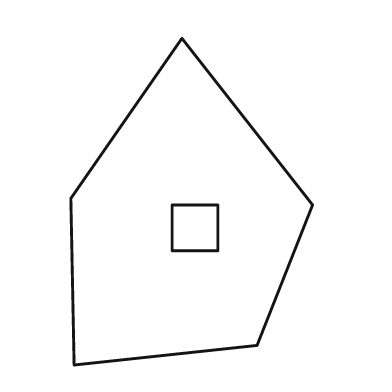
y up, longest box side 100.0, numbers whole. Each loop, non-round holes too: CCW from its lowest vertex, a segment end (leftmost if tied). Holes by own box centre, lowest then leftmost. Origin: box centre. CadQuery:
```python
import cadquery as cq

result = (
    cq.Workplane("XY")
    .moveTo(-36.0, -50.0)
    .lineTo(20.0, -44.0)
    .lineTo(37.0, -1.0)
    .lineTo(-3.0, 50.0)
    .lineTo(-37.0, 1.0)
    .close()
    .moveTo(-6.0, -15.0)
    .lineTo(8.0, -15.0)
    .lineTo(8.0, -1.0)
    .lineTo(-6.0, -1.0)
    .close()
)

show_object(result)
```